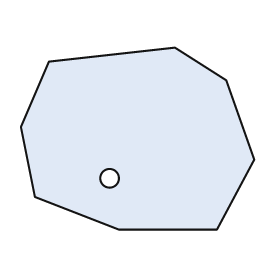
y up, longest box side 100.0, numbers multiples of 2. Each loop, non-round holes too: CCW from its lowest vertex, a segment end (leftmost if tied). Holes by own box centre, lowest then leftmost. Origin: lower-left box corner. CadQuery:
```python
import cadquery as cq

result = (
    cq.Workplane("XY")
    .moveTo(42.0, 0.0)
    .lineTo(84.0, 0.0)
    .lineTo(100.0, 30.0)
    .lineTo(88.0, 64.0)
    .lineTo(66.0, 78.0)
    .lineTo(12.0, 72.0)
    .lineTo(0.0, 44.0)
    .lineTo(6.0, 14.0)
    .close()
    .moveTo(38.0, 22.0)
    .circle(4.0)
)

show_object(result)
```